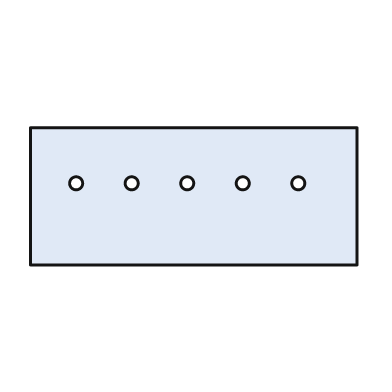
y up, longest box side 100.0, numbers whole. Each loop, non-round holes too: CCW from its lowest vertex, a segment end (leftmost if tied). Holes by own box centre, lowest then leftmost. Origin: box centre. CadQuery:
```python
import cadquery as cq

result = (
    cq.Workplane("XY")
    .moveTo(-50.0, -21.0)
    .lineTo(50.0, -21.0)
    .lineTo(50.0, 21.0)
    .lineTo(-50.0, 21.0)
    .close()
    .moveTo(-36.0, 4.0)
    .circle(2.0)
    .moveTo(-19.0, 4.0)
    .circle(2.0)
    .moveTo(-2.0, 4.0)
    .circle(2.0)
    .moveTo(15.0, 4.0)
    .circle(2.0)
    .moveTo(32.0, 4.0)
    .circle(2.0)
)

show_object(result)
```